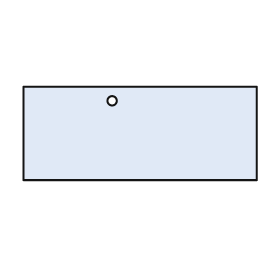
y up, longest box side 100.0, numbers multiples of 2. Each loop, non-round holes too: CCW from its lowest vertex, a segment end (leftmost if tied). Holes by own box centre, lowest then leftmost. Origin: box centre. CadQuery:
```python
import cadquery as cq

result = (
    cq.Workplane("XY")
    .moveTo(-50.0, -20.0)
    .lineTo(50.0, -20.0)
    .lineTo(50.0, 20.0)
    .lineTo(-50.0, 20.0)
    .close()
    .moveTo(-12.0, 14.0)
    .circle(2.0)
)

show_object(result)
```